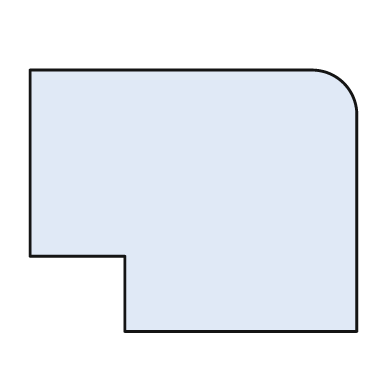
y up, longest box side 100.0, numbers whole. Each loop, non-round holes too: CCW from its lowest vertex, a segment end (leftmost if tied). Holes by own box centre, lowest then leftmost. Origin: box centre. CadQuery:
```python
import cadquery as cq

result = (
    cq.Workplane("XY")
    .moveTo(-21.0, -40.0)
    .lineTo(50.0, -40.0)
    .lineTo(50.0, 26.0)
    .threePointArc((46.0, 36.0), (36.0, 40.0))
    .lineTo(-50.0, 40.0)
    .lineTo(-50.0, -17.0)
    .lineTo(-21.0, -17.0)
    .close()
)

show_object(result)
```